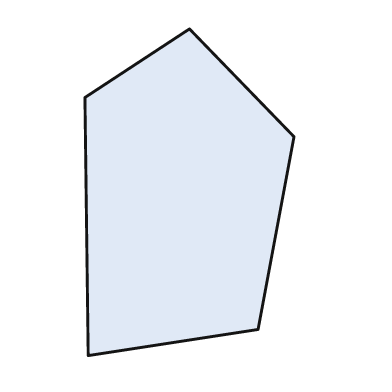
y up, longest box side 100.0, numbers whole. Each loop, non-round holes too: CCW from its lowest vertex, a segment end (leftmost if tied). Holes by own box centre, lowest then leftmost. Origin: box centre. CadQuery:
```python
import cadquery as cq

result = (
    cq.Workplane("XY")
    .moveTo(-31.0, -50.0)
    .lineTo(21.0, -42.0)
    .lineTo(32.0, 17.0)
    .lineTo(0.0, 50.0)
    .lineTo(-32.0, 29.0)
    .close()
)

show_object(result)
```